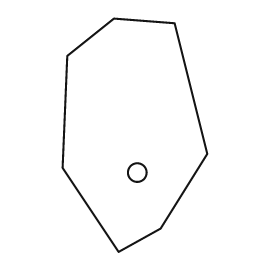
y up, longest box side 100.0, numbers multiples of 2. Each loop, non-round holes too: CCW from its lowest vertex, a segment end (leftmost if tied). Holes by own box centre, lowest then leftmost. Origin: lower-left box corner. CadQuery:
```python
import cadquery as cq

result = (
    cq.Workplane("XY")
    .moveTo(24.0, 0.0)
    .lineTo(42.0, 10.0)
    .lineTo(62.0, 42.0)
    .lineTo(48.0, 98.0)
    .lineTo(22.0, 100.0)
    .lineTo(2.0, 84.0)
    .lineTo(0.0, 36.0)
    .close()
    .moveTo(32.0, 34.0)
    .circle(4.0)
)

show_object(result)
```